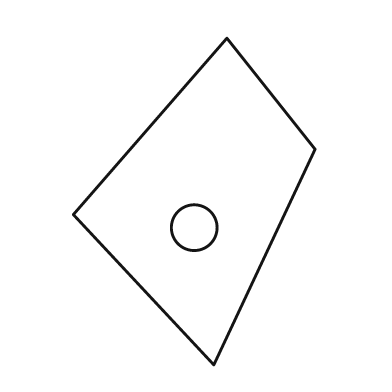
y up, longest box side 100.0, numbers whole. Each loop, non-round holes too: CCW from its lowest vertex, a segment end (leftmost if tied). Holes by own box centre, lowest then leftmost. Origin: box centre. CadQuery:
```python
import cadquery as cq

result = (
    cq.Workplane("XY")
    .moveTo(6.0, -50.0)
    .lineTo(37.0, 16.0)
    .lineTo(10.0, 50.0)
    .lineTo(-37.0, -4.0)
    .close()
    .moveTo(0.0, -8.0)
    .circle(7.0)
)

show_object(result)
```